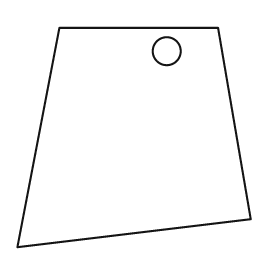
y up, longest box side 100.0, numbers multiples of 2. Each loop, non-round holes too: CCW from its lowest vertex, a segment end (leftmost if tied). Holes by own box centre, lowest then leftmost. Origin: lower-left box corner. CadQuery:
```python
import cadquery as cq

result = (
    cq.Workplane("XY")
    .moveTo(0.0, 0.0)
    .lineTo(100.0, 12.0)
    .lineTo(86.0, 94.0)
    .lineTo(18.0, 94.0)
    .close()
    .moveTo(64.0, 84.0)
    .circle(6.0)
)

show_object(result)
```